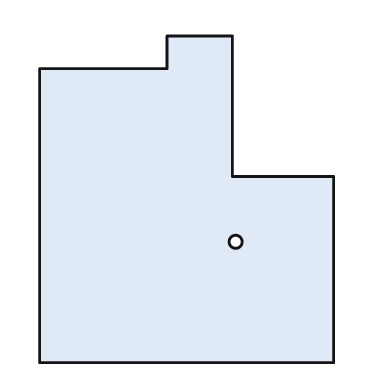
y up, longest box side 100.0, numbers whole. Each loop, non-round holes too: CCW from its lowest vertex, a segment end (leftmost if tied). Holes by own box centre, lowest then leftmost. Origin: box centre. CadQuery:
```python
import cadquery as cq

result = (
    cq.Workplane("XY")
    .moveTo(-45.0, -50.0)
    .lineTo(45.0, -50.0)
    .lineTo(45.0, 7.0)
    .lineTo(14.0, 7.0)
    .lineTo(14.0, 50.0)
    .lineTo(-6.0, 50.0)
    .lineTo(-6.0, 40.0)
    .lineTo(-45.0, 40.0)
    .close()
    .moveTo(15.0, -13.0)
    .circle(2.0)
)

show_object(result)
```